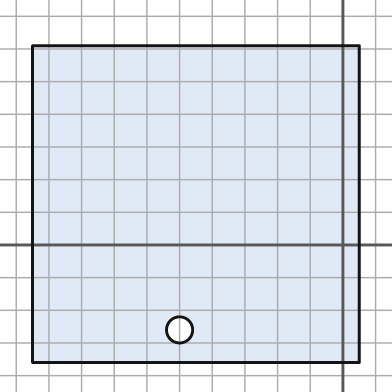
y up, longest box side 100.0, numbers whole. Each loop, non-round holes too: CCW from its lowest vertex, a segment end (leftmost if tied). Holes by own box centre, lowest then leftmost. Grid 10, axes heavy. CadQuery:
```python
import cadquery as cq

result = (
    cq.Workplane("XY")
    .moveTo(-95.0, -36.0)
    .lineTo(5.0, -36.0)
    .lineTo(5.0, 61.0)
    .lineTo(-95.0, 61.0)
    .close()
    .moveTo(-50.0, -26.0)
    .circle(4.0)
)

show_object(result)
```